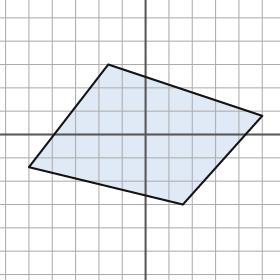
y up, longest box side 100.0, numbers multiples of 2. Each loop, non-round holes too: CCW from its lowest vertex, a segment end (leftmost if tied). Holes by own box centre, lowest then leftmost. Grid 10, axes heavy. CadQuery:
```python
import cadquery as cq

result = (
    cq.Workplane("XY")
    .moveTo(16.0, -30.0)
    .lineTo(50.0, 8.0)
    .lineTo(-16.0, 30.0)
    .lineTo(-50.0, -14.0)
    .close()
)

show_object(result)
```